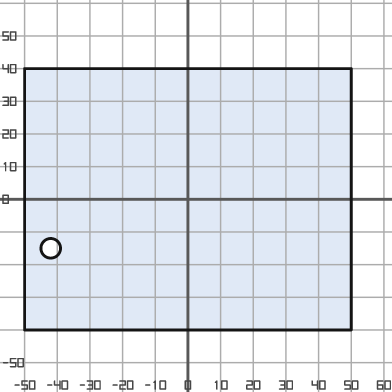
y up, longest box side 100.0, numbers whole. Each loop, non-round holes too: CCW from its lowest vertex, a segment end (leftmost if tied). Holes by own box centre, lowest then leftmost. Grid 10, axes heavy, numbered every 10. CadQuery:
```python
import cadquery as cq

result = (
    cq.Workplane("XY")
    .moveTo(-50.0, -40.0)
    .lineTo(50.0, -40.0)
    .lineTo(50.0, 40.0)
    .lineTo(-50.0, 40.0)
    .close()
    .moveTo(-42.0, -15.0)
    .circle(3.0)
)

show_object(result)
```